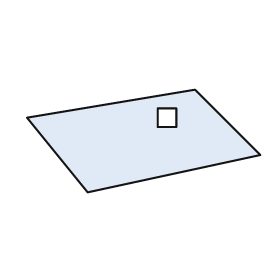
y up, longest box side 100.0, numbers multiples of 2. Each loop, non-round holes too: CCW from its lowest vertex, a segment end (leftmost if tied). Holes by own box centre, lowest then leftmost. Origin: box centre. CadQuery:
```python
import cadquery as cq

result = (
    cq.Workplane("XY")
    .moveTo(-24.0, -22.0)
    .lineTo(50.0, -6.0)
    .lineTo(22.0, 22.0)
    .lineTo(-50.0, 10.0)
    .close()
    .moveTo(6.0, 6.0)
    .lineTo(14.0, 6.0)
    .lineTo(14.0, 14.0)
    .lineTo(6.0, 14.0)
    .close()
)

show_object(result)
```